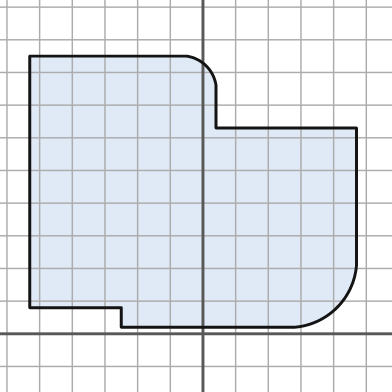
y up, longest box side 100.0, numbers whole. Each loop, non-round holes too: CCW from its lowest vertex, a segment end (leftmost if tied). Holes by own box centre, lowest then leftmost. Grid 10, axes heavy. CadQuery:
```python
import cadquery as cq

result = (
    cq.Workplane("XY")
    .moveTo(-25.0, 2.0)
    .lineTo(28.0, 2.0)
    .threePointArc((41.0, 8.0), (47.0, 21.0))
    .lineTo(47.0, 63.0)
    .lineTo(4.0, 63.0)
    .lineTo(4.0, 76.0)
    .threePointArc((1.0, 82.0), (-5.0, 85.0))
    .lineTo(-53.0, 85.0)
    .lineTo(-53.0, 8.0)
    .lineTo(-25.0, 8.0)
    .close()
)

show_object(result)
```